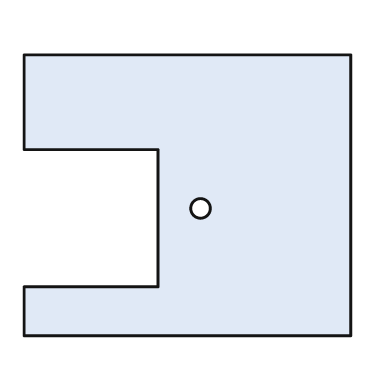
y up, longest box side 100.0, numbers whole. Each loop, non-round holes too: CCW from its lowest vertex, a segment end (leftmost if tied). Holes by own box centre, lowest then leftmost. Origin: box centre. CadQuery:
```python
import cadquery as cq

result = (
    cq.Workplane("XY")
    .moveTo(-50.0, -43.0)
    .lineTo(50.0, -43.0)
    .lineTo(50.0, 43.0)
    .lineTo(-50.0, 43.0)
    .lineTo(-50.0, 14.0)
    .lineTo(-9.0, 14.0)
    .lineTo(-9.0, -28.0)
    .lineTo(-50.0, -28.0)
    .close()
    .moveTo(4.0, -4.0)
    .circle(3.0)
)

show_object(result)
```